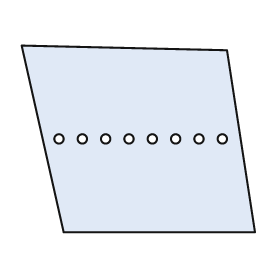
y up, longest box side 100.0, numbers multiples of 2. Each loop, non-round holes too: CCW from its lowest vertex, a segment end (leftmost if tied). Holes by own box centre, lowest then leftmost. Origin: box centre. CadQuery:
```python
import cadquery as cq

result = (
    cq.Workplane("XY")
    .moveTo(-32.0, -40.0)
    .lineTo(50.0, -40.0)
    .lineTo(38.0, 38.0)
    .lineTo(-50.0, 40.0)
    .close()
    .moveTo(-34.0, 0.0)
    .circle(2.0)
    .moveTo(-24.0, 0.0)
    .circle(2.0)
    .moveTo(-14.0, 0.0)
    .circle(2.0)
    .moveTo(-4.0, 0.0)
    .circle(2.0)
    .moveTo(6.0, 0.0)
    .circle(2.0)
    .moveTo(16.0, 0.0)
    .circle(2.0)
    .moveTo(26.0, 0.0)
    .circle(2.0)
    .moveTo(36.0, 0.0)
    .circle(2.0)
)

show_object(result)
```